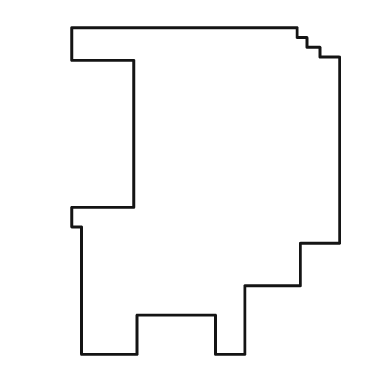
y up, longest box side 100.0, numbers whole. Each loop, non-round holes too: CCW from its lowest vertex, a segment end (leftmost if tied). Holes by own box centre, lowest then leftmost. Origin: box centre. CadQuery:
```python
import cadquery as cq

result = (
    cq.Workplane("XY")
    .moveTo(-38.0, -50.0)
    .lineTo(-21.0, -50.0)
    .lineTo(-21.0, -38.0)
    .lineTo(3.0, -38.0)
    .lineTo(3.0, -50.0)
    .lineTo(12.0, -50.0)
    .lineTo(12.0, -29.0)
    .lineTo(29.0, -29.0)
    .lineTo(29.0, -16.0)
    .lineTo(41.0, -16.0)
    .lineTo(41.0, 41.0)
    .lineTo(35.0, 41.0)
    .lineTo(35.0, 44.0)
    .lineTo(31.0, 44.0)
    .lineTo(31.0, 47.0)
    .lineTo(28.0, 47.0)
    .lineTo(28.0, 50.0)
    .lineTo(-41.0, 50.0)
    .lineTo(-41.0, 40.0)
    .lineTo(-22.0, 40.0)
    .lineTo(-22.0, -5.0)
    .lineTo(-41.0, -5.0)
    .lineTo(-41.0, -11.0)
    .lineTo(-38.0, -11.0)
    .close()
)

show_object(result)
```